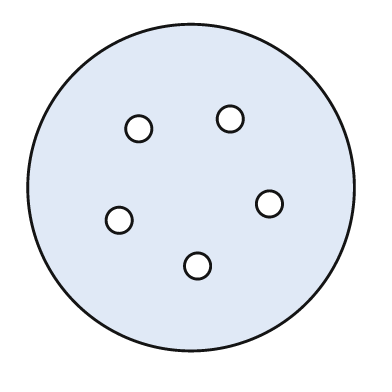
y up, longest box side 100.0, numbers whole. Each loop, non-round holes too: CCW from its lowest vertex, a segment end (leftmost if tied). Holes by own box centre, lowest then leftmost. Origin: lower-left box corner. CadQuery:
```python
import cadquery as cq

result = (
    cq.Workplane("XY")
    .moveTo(50.0, 50.0)
    .circle(50.0)
    .moveTo(52.0, 26.0)
    .circle(4.0)
    .moveTo(28.0, 40.0)
    .circle(4.0)
    .moveTo(74.0, 45.0)
    .circle(4.0)
    .moveTo(34.0, 68.0)
    .circle(4.0)
    .moveTo(62.0, 71.0)
    .circle(4.0)
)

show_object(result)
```